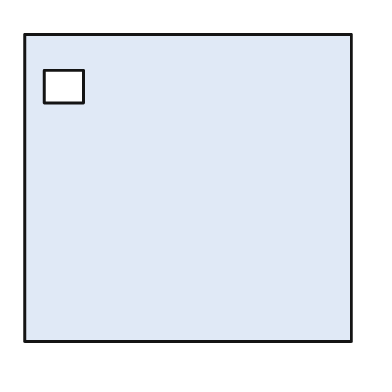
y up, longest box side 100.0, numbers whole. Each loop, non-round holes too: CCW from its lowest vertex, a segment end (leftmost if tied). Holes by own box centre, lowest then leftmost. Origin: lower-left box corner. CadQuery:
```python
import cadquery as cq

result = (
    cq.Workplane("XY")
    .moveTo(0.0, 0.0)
    .lineTo(100.0, 0.0)
    .lineTo(100.0, 94.0)
    .lineTo(0.0, 94.0)
    .close()
    .moveTo(6.0, 73.0)
    .lineTo(18.0, 73.0)
    .lineTo(18.0, 83.0)
    .lineTo(6.0, 83.0)
    .close()
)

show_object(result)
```